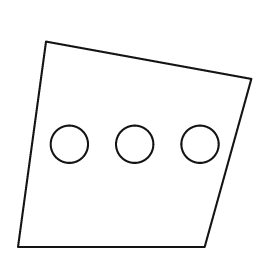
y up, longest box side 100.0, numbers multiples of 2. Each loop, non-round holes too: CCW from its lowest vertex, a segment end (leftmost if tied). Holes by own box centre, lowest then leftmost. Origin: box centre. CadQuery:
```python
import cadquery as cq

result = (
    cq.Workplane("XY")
    .moveTo(-50.0, -44.0)
    .lineTo(30.0, -44.0)
    .lineTo(50.0, 28.0)
    .lineTo(-38.0, 44.0)
    .close()
    .moveTo(-28.0, 0.0)
    .circle(8.0)
    .moveTo(0.0, 0.0)
    .circle(8.0)
    .moveTo(28.0, 0.0)
    .circle(8.0)
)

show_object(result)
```